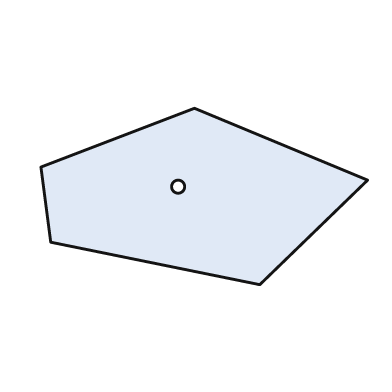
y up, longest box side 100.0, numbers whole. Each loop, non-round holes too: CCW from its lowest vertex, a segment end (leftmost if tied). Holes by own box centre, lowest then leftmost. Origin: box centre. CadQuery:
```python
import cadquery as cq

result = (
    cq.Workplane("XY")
    .moveTo(17.0, -27.0)
    .lineTo(50.0, 5.0)
    .lineTo(-3.0, 27.0)
    .lineTo(-50.0, 9.0)
    .lineTo(-47.0, -14.0)
    .close()
    .moveTo(-8.0, 3.0)
    .circle(2.0)
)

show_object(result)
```